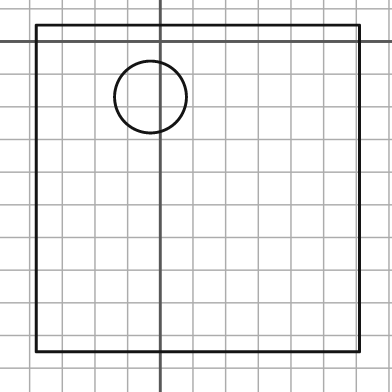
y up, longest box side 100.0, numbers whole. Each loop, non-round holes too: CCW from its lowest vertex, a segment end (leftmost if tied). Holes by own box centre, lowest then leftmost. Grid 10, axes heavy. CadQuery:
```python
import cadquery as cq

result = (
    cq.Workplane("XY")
    .moveTo(-38.0, -95.0)
    .lineTo(61.0, -95.0)
    .lineTo(61.0, 5.0)
    .lineTo(-38.0, 5.0)
    .close()
    .moveTo(-3.0, -17.0)
    .circle(11.0)
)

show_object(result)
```